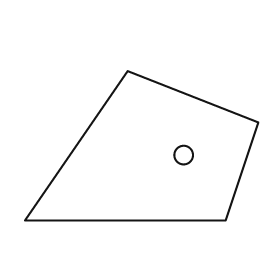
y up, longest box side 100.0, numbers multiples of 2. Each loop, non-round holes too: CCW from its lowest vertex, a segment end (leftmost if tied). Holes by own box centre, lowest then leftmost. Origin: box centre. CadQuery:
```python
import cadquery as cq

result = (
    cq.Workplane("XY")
    .moveTo(-50.0, -32.0)
    .lineTo(36.0, -32.0)
    .lineTo(50.0, 10.0)
    .lineTo(-6.0, 32.0)
    .close()
    .moveTo(18.0, -4.0)
    .circle(4.0)
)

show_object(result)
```